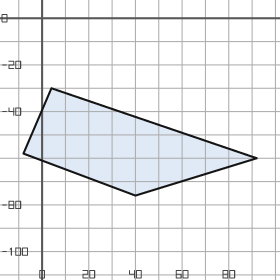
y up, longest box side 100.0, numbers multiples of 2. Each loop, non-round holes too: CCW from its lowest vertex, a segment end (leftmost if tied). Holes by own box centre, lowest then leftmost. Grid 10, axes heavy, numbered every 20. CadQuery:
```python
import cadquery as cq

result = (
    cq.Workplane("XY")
    .moveTo(40.0, -76.0)
    .lineTo(92.0, -60.0)
    .lineTo(4.0, -30.0)
    .lineTo(-8.0, -58.0)
    .close()
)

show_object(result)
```